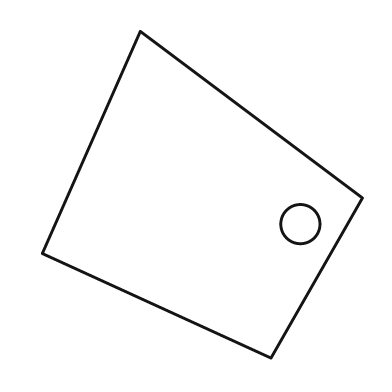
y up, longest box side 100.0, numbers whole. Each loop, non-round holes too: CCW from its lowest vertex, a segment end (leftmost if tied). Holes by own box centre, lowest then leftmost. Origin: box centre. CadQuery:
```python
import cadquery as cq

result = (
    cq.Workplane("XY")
    .moveTo(21.0, -50.0)
    .lineTo(49.0, -1.0)
    .lineTo(-19.0, 50.0)
    .lineTo(-49.0, -18.0)
    .close()
    .moveTo(30.0, -9.0)
    .circle(6.0)
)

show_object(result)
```